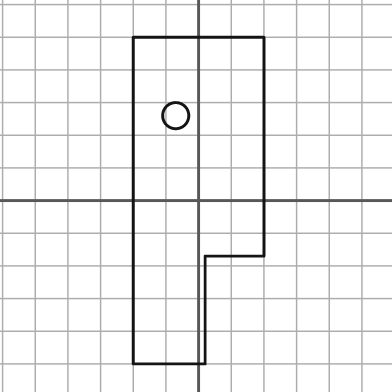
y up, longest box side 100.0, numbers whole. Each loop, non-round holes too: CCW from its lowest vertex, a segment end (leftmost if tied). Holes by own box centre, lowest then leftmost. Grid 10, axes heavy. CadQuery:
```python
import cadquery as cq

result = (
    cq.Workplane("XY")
    .moveTo(-20.0, -50.0)
    .lineTo(2.0, -50.0)
    .lineTo(2.0, -17.0)
    .lineTo(20.0, -17.0)
    .lineTo(20.0, 50.0)
    .lineTo(-20.0, 50.0)
    .close()
    .moveTo(-7.0, 26.0)
    .circle(4.0)
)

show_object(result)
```